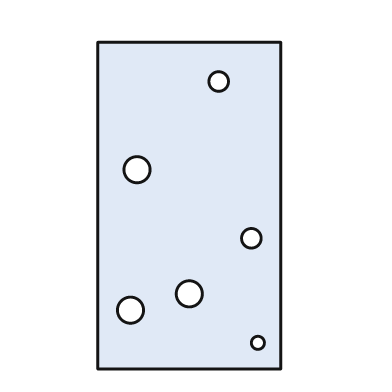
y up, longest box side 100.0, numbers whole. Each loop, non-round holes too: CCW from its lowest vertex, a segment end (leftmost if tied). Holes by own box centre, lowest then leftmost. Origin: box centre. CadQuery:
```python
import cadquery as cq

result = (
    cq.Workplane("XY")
    .moveTo(-28.0, -50.0)
    .lineTo(28.0, -50.0)
    .lineTo(28.0, 50.0)
    .lineTo(-28.0, 50.0)
    .close()
    .moveTo(21.0, -42.0)
    .circle(2.0)
    .moveTo(-18.0, -32.0)
    .circle(4.0)
    .moveTo(0.0, -27.0)
    .circle(4.0)
    .moveTo(19.0, -10.0)
    .circle(3.0)
    .moveTo(-16.0, 11.0)
    .circle(4.0)
    .moveTo(9.0, 38.0)
    .circle(3.0)
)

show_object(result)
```